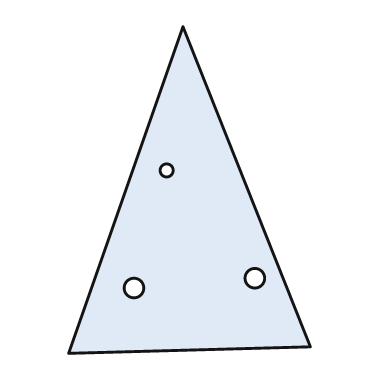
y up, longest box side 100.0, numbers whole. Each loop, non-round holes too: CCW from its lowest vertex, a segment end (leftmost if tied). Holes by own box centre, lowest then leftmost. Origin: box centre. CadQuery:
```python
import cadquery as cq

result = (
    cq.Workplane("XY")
    .moveTo(-37.0, -50.0)
    .lineTo(37.0, -48.0)
    .lineTo(-2.0, 50.0)
    .close()
    .moveTo(-17.0, -30.0)
    .circle(3.0)
    .moveTo(20.0, -27.0)
    .circle(3.0)
    .moveTo(-7.0, 6.0)
    .circle(2.0)
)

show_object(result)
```